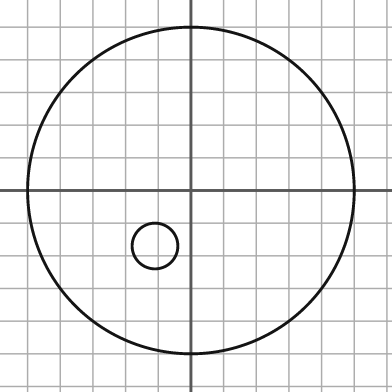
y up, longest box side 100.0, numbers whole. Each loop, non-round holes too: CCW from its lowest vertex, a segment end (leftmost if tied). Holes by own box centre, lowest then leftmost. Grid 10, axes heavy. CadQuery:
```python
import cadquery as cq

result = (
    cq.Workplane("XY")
    .moveTo(0.0, 0.0)
    .circle(50.0)
    .moveTo(-11.0, -17.0)
    .circle(7.0)
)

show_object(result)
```